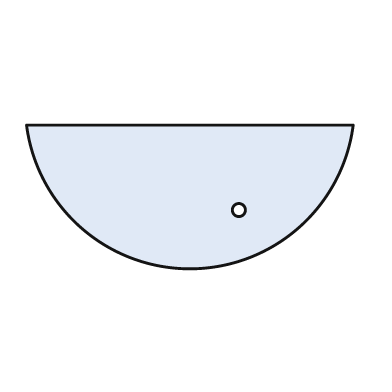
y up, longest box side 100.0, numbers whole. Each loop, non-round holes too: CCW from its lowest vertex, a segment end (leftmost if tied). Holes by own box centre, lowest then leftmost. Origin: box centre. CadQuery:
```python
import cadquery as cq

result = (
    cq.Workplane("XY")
    .moveTo(-50.0, 22.0)
    .threePointArc((0.0, -22.0), (50.0, 22.0))
    .close()
    .moveTo(15.0, -4.0)
    .circle(2.0)
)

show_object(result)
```